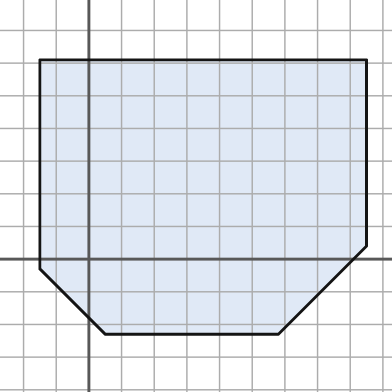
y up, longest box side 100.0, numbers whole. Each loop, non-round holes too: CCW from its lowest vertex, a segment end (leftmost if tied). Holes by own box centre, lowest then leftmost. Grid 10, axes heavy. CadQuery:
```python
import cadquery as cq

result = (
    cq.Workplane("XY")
    .moveTo(5.0, -23.0)
    .lineTo(58.0, -23.0)
    .lineTo(85.0, 4.0)
    .lineTo(85.0, 61.0)
    .lineTo(-15.0, 61.0)
    .lineTo(-15.0, -3.0)
    .close()
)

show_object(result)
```